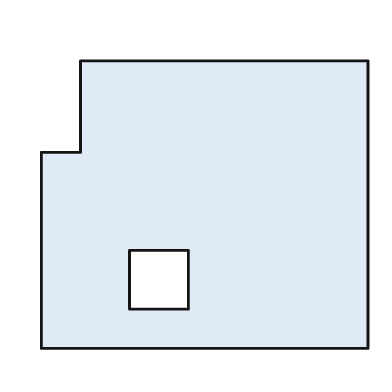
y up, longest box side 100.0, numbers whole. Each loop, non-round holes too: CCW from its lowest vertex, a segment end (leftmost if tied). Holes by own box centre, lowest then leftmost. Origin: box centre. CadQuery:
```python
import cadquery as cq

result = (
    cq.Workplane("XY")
    .moveTo(-50.0, -44.0)
    .lineTo(50.0, -44.0)
    .lineTo(50.0, 44.0)
    .lineTo(-38.0, 44.0)
    .lineTo(-38.0, 16.0)
    .lineTo(-50.0, 16.0)
    .close()
    .moveTo(-23.0, -32.0)
    .lineTo(-5.0, -32.0)
    .lineTo(-5.0, -14.0)
    .lineTo(-23.0, -14.0)
    .close()
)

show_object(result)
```